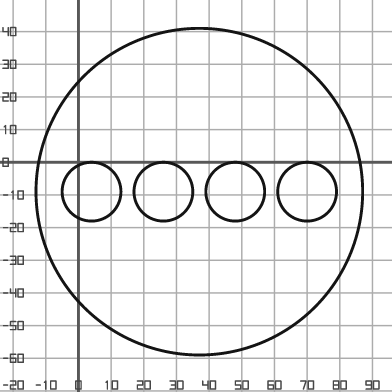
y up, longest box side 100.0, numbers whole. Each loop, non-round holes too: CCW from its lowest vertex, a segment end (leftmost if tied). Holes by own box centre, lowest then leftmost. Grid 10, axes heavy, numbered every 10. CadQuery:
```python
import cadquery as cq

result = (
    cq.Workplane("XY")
    .moveTo(37.0, -9.0)
    .circle(50.0)
    .moveTo(4.0, -9.0)
    .circle(9.0)
    .moveTo(26.0, -9.0)
    .circle(9.0)
    .moveTo(48.0, -9.0)
    .circle(9.0)
    .moveTo(70.0, -9.0)
    .circle(9.0)
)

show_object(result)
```